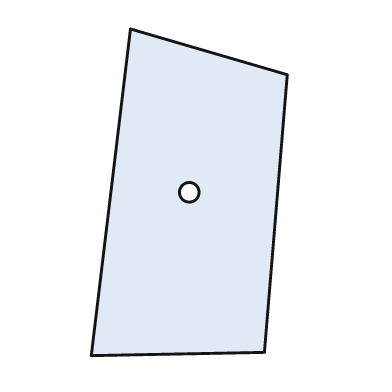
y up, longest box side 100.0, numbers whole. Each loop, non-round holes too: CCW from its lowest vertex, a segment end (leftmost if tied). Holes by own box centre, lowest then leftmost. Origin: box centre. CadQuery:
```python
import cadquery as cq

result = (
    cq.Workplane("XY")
    .moveTo(-30.0, -50.0)
    .lineTo(23.0, -49.0)
    .lineTo(30.0, 36.0)
    .lineTo(-18.0, 50.0)
    .close()
    .moveTo(0.0, 0.0)
    .circle(3.0)
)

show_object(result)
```